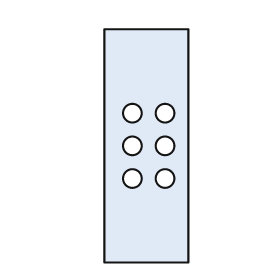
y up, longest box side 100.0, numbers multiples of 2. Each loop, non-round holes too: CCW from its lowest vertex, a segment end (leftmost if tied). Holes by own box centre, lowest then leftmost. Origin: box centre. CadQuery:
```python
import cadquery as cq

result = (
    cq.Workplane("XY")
    .moveTo(-18.0, -50.0)
    .lineTo(18.0, -50.0)
    .lineTo(18.0, 50.0)
    .lineTo(-18.0, 50.0)
    .close()
    .moveTo(-6.0, -14.0)
    .circle(4.0)
    .moveTo(8.0, -14.0)
    .circle(4.0)
    .moveTo(-6.0, 0.0)
    .circle(4.0)
    .moveTo(8.0, 0.0)
    .circle(4.0)
    .moveTo(-6.0, 14.0)
    .circle(4.0)
    .moveTo(8.0, 14.0)
    .circle(4.0)
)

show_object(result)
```